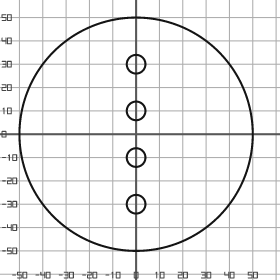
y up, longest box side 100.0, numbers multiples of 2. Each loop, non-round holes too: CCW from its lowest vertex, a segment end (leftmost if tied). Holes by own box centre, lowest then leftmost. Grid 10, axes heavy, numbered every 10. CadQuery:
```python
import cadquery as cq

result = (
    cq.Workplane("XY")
    .moveTo(0.0, 0.0)
    .circle(50.0)
    .moveTo(0.0, -30.0)
    .circle(4.0)
    .moveTo(0.0, -10.0)
    .circle(4.0)
    .moveTo(0.0, 10.0)
    .circle(4.0)
    .moveTo(0.0, 30.0)
    .circle(4.0)
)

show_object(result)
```